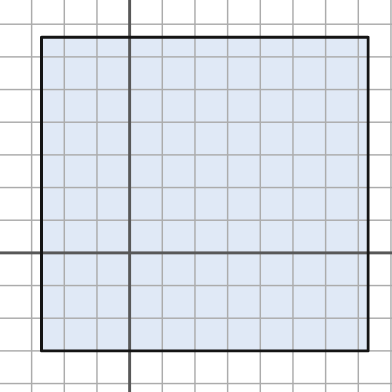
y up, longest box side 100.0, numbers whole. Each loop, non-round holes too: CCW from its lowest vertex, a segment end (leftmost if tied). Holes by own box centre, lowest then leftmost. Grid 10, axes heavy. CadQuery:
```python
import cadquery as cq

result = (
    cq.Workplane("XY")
    .moveTo(-27.0, -30.0)
    .lineTo(73.0, -30.0)
    .lineTo(73.0, 66.0)
    .lineTo(-27.0, 66.0)
    .close()
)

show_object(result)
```